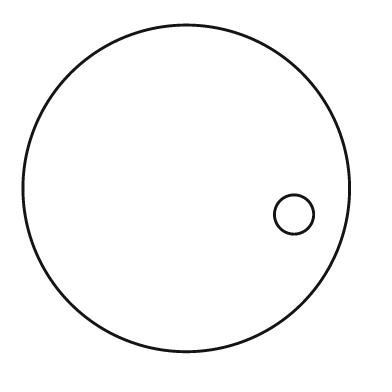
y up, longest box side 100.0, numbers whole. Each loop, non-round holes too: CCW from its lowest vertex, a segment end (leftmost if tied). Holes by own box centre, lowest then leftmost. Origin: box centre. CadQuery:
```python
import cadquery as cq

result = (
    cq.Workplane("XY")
    .moveTo(0.0, 0.0)
    .circle(50.0)
    .moveTo(33.0, -8.0)
    .circle(6.0)
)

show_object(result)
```